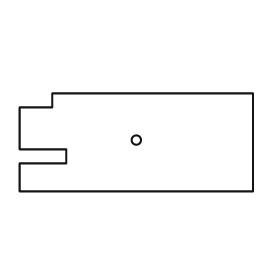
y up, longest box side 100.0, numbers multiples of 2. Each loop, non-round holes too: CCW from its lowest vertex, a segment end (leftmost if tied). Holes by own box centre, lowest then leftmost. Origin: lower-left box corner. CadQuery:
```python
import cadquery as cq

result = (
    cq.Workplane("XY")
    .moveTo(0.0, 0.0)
    .lineTo(100.0, 0.0)
    .lineTo(100.0, 42.0)
    .lineTo(14.0, 42.0)
    .lineTo(14.0, 36.0)
    .lineTo(0.0, 36.0)
    .lineTo(0.0, 18.0)
    .lineTo(20.0, 18.0)
    .lineTo(20.0, 12.0)
    .lineTo(0.0, 12.0)
    .close()
    .moveTo(50.0, 22.0)
    .circle(2.0)
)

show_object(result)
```